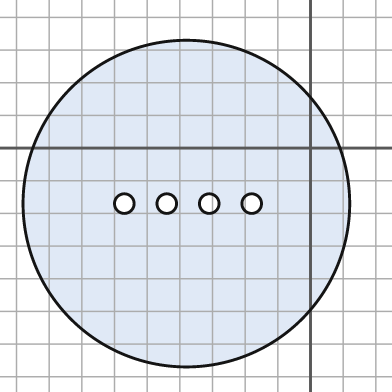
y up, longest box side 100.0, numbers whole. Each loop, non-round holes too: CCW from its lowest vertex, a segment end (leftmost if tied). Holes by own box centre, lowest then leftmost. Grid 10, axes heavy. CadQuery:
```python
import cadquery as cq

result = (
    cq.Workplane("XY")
    .moveTo(-38.0, -17.0)
    .circle(50.0)
    .moveTo(-57.0, -17.0)
    .circle(3.0)
    .moveTo(-44.0, -17.0)
    .circle(3.0)
    .moveTo(-31.0, -17.0)
    .circle(3.0)
    .moveTo(-18.0, -17.0)
    .circle(3.0)
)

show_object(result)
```